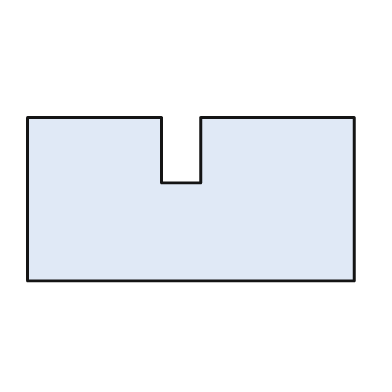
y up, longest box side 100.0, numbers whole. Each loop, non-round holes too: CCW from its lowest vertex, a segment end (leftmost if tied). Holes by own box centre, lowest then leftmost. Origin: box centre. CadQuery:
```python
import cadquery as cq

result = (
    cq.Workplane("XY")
    .moveTo(-50.0, -25.0)
    .lineTo(50.0, -25.0)
    .lineTo(50.0, 25.0)
    .lineTo(3.0, 25.0)
    .lineTo(3.0, 5.0)
    .lineTo(-9.0, 5.0)
    .lineTo(-9.0, 25.0)
    .lineTo(-50.0, 25.0)
    .close()
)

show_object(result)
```